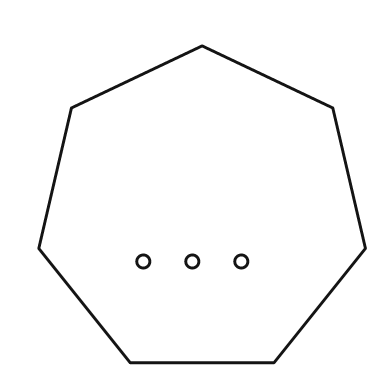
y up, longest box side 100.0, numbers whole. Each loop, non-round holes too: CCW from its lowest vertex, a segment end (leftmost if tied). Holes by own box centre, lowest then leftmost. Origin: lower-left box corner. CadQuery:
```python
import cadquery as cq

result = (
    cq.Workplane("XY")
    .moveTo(28.0, 0.0)
    .lineTo(72.0, 0.0)
    .lineTo(100.0, 35.0)
    .lineTo(90.0, 78.0)
    .lineTo(50.0, 97.0)
    .lineTo(10.0, 78.0)
    .lineTo(0.0, 35.0)
    .close()
    .moveTo(32.0, 31.0)
    .circle(2.0)
    .moveTo(47.0, 31.0)
    .circle(2.0)
    .moveTo(62.0, 31.0)
    .circle(2.0)
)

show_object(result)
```